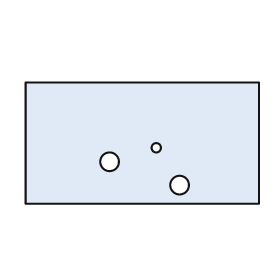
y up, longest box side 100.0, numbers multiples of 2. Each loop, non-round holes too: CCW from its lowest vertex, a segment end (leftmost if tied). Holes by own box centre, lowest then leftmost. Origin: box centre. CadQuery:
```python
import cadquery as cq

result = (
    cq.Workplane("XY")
    .moveTo(-50.0, -26.0)
    .lineTo(50.0, -26.0)
    .lineTo(50.0, 26.0)
    .lineTo(-50.0, 26.0)
    .close()
    .moveTo(16.0, -18.0)
    .circle(4.0)
    .moveTo(-14.0, -8.0)
    .circle(4.0)
    .moveTo(6.0, -2.0)
    .circle(2.0)
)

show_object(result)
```